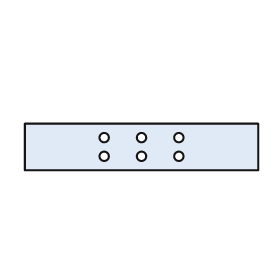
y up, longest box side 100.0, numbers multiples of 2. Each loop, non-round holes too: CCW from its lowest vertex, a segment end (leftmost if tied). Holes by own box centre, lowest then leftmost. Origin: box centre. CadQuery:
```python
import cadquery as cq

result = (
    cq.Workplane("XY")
    .moveTo(-50.0, -10.0)
    .lineTo(50.0, -10.0)
    .lineTo(50.0, 10.0)
    .lineTo(-50.0, 10.0)
    .close()
    .moveTo(-16.0, -4.0)
    .circle(2.0)
    .moveTo(0.0, -4.0)
    .circle(2.0)
    .moveTo(16.0, -4.0)
    .circle(2.0)
    .moveTo(-16.0, 4.0)
    .circle(2.0)
    .moveTo(0.0, 4.0)
    .circle(2.0)
    .moveTo(16.0, 4.0)
    .circle(2.0)
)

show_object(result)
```